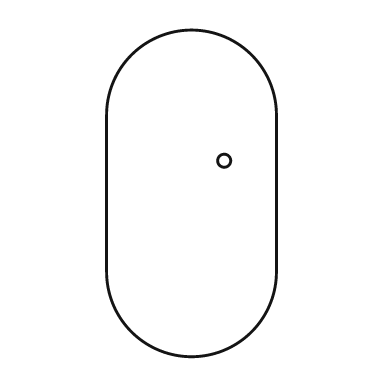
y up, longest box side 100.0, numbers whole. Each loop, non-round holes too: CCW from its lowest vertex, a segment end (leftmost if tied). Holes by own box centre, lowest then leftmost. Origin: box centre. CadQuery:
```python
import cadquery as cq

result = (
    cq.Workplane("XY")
    .moveTo(-26.0, -24.0)
    .threePointArc((0.0, -50.0), (26.0, -24.0))
    .lineTo(26.0, 24.0)
    .threePointArc((0.0, 50.0), (-26.0, 24.0))
    .close()
    .moveTo(10.0, 10.0)
    .circle(2.0)
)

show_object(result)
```